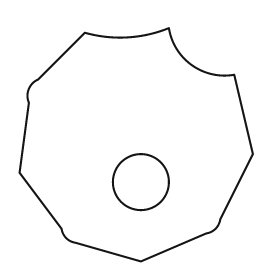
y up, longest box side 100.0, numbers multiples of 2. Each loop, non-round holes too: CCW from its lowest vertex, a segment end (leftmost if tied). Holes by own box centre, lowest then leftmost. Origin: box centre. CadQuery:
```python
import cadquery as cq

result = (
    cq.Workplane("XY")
    .moveTo(2.0, -50.0)
    .lineTo(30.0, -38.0)
    .threePointArc((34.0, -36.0), (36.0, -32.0))
    .lineTo(50.0, -4.0)
    .lineTo(42.0, 30.0)
    .threePointArc((24.0, 34.0), (14.0, 50.0))
    .threePointArc((-4.0, 46.0), (-22.0, 48.0))
    .lineTo(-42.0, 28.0)
    .threePointArc((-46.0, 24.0), (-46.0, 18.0))
    .lineTo(-50.0, -12.0)
    .lineTo(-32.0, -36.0)
    .threePointArc((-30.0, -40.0), (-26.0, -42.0))
    .close()
    .moveTo(2.0, -16.0)
    .circle(12.0)
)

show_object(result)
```